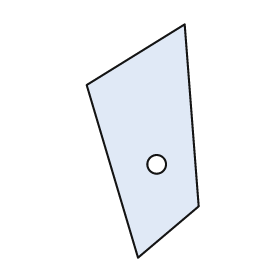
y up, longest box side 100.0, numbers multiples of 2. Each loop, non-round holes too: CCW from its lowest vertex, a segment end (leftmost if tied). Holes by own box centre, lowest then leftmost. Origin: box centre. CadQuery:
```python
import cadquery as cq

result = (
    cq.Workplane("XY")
    .moveTo(-2.0, -50.0)
    .lineTo(24.0, -28.0)
    .lineTo(18.0, 50.0)
    .lineTo(-24.0, 24.0)
    .close()
    .moveTo(6.0, -10.0)
    .circle(4.0)
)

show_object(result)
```